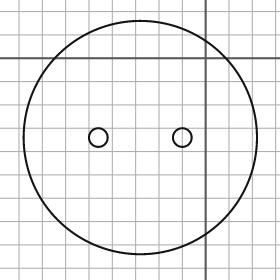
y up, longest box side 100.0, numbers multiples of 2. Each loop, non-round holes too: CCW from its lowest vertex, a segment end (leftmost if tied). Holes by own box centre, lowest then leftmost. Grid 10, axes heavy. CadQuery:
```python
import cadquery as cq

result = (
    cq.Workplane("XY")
    .moveTo(-28.0, -34.0)
    .circle(50.0)
    .moveTo(-46.0, -34.0)
    .circle(4.0)
    .moveTo(-10.0, -34.0)
    .circle(4.0)
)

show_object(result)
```